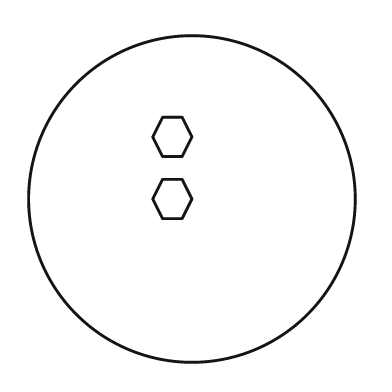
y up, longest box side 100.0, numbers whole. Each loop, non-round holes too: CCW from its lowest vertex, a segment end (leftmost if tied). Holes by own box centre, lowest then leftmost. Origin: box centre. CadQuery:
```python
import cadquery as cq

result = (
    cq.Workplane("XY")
    .moveTo(0.0, 0.0)
    .circle(50.0)
    .moveTo(-9.0, -6.0)
    .lineTo(-3.0, -6.0)
    .lineTo(0.0, 0.0)
    .lineTo(-3.0, 6.0)
    .lineTo(-9.0, 6.0)
    .lineTo(-12.0, 0.0)
    .close()
    .moveTo(-9.0, 13.0)
    .lineTo(-3.0, 13.0)
    .lineTo(0.0, 19.0)
    .lineTo(-3.0, 25.0)
    .lineTo(-9.0, 25.0)
    .lineTo(-12.0, 19.0)
    .close()
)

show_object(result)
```